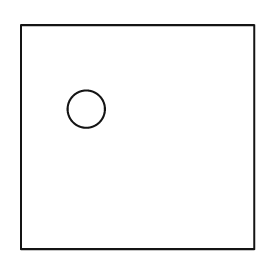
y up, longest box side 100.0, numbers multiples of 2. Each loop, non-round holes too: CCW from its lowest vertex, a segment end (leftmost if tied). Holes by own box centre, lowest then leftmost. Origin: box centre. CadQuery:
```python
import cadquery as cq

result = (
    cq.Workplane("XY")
    .moveTo(-50.0, -48.0)
    .lineTo(50.0, -48.0)
    .lineTo(50.0, 48.0)
    .lineTo(-50.0, 48.0)
    .close()
    .moveTo(-22.0, 12.0)
    .circle(8.0)
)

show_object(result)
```